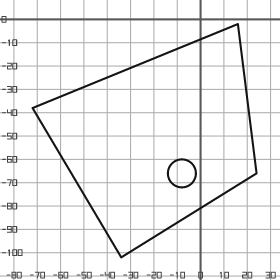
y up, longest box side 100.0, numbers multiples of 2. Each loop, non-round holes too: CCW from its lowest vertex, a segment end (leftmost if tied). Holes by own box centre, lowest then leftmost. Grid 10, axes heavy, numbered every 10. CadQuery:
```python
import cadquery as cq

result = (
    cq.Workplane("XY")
    .moveTo(-34.0, -102.0)
    .lineTo(24.0, -66.0)
    .lineTo(16.0, -2.0)
    .lineTo(-72.0, -38.0)
    .close()
    .moveTo(-8.0, -66.0)
    .circle(6.0)
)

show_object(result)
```